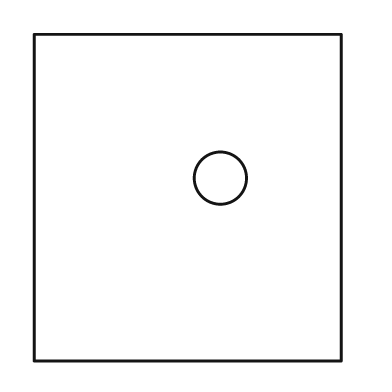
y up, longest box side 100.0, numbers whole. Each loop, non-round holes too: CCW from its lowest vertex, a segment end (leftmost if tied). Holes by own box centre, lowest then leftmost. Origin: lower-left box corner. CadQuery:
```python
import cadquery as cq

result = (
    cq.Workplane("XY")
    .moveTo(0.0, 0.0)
    .lineTo(94.0, 0.0)
    .lineTo(94.0, 100.0)
    .lineTo(0.0, 100.0)
    .close()
    .moveTo(57.0, 56.0)
    .circle(8.0)
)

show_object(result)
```